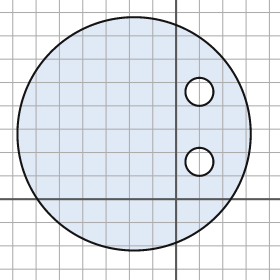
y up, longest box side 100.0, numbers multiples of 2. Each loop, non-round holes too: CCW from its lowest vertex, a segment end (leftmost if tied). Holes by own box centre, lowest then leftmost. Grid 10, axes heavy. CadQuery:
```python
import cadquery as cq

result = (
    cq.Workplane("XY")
    .moveTo(-18.0, 28.0)
    .circle(50.0)
    .moveTo(10.0, 16.0)
    .circle(6.0)
    .moveTo(10.0, 46.0)
    .circle(6.0)
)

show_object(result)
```